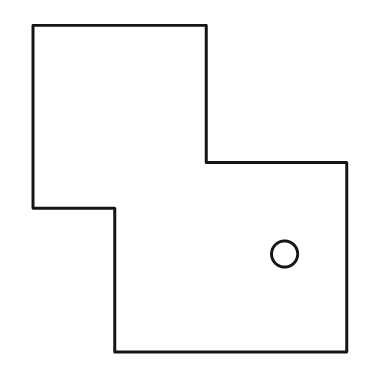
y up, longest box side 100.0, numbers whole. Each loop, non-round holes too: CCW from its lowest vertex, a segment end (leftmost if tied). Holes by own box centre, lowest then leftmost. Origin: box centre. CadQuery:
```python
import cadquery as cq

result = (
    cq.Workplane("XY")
    .moveTo(-23.0, -50.0)
    .lineTo(48.0, -50.0)
    .lineTo(48.0, 8.0)
    .lineTo(5.0, 8.0)
    .lineTo(5.0, 50.0)
    .lineTo(-48.0, 50.0)
    .lineTo(-48.0, -6.0)
    .lineTo(-23.0, -6.0)
    .close()
    .moveTo(29.0, -20.0)
    .circle(4.0)
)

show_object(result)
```